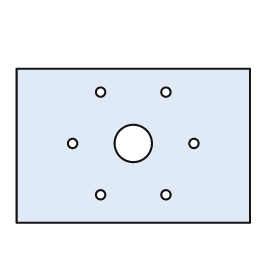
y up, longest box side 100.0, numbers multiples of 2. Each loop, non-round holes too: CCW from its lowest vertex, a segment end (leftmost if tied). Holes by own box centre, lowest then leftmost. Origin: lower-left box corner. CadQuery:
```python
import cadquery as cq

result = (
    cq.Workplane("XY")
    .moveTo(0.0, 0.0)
    .lineTo(100.0, 0.0)
    .lineTo(100.0, 66.0)
    .lineTo(0.0, 66.0)
    .close()
    .moveTo(36.0, 12.0)
    .circle(2.0)
    .moveTo(64.0, 12.0)
    .circle(2.0)
    .moveTo(24.0, 34.0)
    .circle(2.0)
    .moveTo(50.0, 34.0)
    .circle(8.0)
    .moveTo(76.0, 34.0)
    .circle(2.0)
    .moveTo(36.0, 56.0)
    .circle(2.0)
    .moveTo(64.0, 56.0)
    .circle(2.0)
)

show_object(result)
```